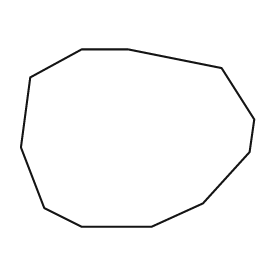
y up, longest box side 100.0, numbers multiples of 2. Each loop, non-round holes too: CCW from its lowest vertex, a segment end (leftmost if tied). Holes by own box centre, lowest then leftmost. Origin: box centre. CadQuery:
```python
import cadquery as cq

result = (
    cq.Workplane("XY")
    .moveTo(-24.0, -38.0)
    .lineTo(6.0, -38.0)
    .lineTo(28.0, -28.0)
    .lineTo(48.0, -6.0)
    .lineTo(50.0, 8.0)
    .lineTo(36.0, 30.0)
    .lineTo(-4.0, 38.0)
    .lineTo(-24.0, 38.0)
    .lineTo(-46.0, 26.0)
    .lineTo(-50.0, -4.0)
    .lineTo(-40.0, -30.0)
    .close()
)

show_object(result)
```